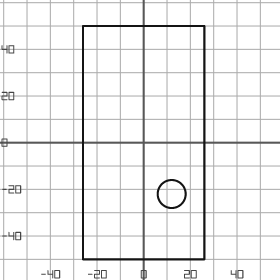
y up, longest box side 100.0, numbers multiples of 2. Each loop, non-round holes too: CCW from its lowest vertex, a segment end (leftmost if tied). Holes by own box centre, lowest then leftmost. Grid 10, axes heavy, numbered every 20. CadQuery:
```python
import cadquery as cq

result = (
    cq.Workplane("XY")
    .moveTo(-26.0, -50.0)
    .lineTo(26.0, -50.0)
    .lineTo(26.0, 50.0)
    .lineTo(-26.0, 50.0)
    .close()
    .moveTo(12.0, -22.0)
    .circle(6.0)
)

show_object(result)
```